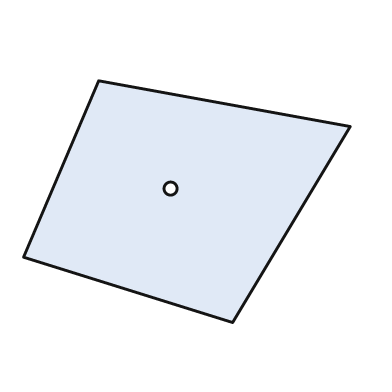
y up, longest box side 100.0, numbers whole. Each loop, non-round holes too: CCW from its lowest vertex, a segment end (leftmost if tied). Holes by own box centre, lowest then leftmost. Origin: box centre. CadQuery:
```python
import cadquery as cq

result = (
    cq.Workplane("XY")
    .moveTo(14.0, -37.0)
    .lineTo(50.0, 23.0)
    .lineTo(-27.0, 37.0)
    .lineTo(-50.0, -17.0)
    .close()
    .moveTo(-5.0, 4.0)
    .circle(2.0)
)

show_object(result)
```